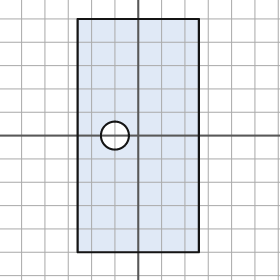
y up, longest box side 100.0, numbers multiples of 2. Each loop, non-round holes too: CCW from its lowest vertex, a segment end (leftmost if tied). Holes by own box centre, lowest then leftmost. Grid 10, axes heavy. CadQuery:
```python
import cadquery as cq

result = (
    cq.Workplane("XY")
    .moveTo(-26.0, -50.0)
    .lineTo(26.0, -50.0)
    .lineTo(26.0, 50.0)
    .lineTo(-26.0, 50.0)
    .close()
    .moveTo(-10.0, 0.0)
    .circle(6.0)
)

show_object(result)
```